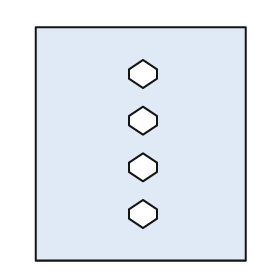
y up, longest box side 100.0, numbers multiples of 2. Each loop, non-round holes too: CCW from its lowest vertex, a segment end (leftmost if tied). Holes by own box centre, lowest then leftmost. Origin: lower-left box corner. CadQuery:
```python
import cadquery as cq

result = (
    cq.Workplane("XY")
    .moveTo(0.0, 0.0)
    .lineTo(90.0, 0.0)
    .lineTo(90.0, 100.0)
    .lineTo(0.0, 100.0)
    .close()
    .moveTo(46.0, 14.0)
    .lineTo(52.0, 18.0)
    .lineTo(52.0, 22.0)
    .lineTo(46.0, 26.0)
    .lineTo(40.0, 22.0)
    .lineTo(40.0, 18.0)
    .close()
    .moveTo(46.0, 34.0)
    .lineTo(52.0, 38.0)
    .lineTo(52.0, 42.0)
    .lineTo(46.0, 46.0)
    .lineTo(40.0, 42.0)
    .lineTo(40.0, 38.0)
    .close()
    .moveTo(46.0, 54.0)
    .lineTo(52.0, 58.0)
    .lineTo(52.0, 62.0)
    .lineTo(46.0, 66.0)
    .lineTo(40.0, 62.0)
    .lineTo(40.0, 58.0)
    .close()
    .moveTo(46.0, 74.0)
    .lineTo(52.0, 78.0)
    .lineTo(52.0, 82.0)
    .lineTo(46.0, 86.0)
    .lineTo(40.0, 82.0)
    .lineTo(40.0, 78.0)
    .close()
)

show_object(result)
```